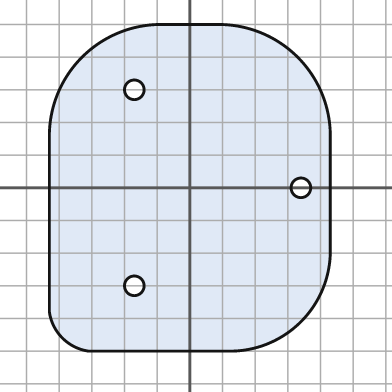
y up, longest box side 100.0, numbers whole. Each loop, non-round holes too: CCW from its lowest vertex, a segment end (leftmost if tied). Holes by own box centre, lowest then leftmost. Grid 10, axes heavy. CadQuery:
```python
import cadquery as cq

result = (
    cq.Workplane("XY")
    .moveTo(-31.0, -50.0)
    .lineTo(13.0, -50.0)
    .threePointArc((34.0, -41.0), (43.0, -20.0))
    .lineTo(43.0, 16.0)
    .threePointArc((33.0, 40.0), (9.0, 50.0))
    .lineTo(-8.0, 50.0)
    .threePointArc((-33.0, 40.0), (-43.0, 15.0))
    .lineTo(-43.0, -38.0)
    .threePointArc((-39.0, -46.0), (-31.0, -50.0))
    .close()
    .moveTo(-17.0, -30.0)
    .circle(3.0)
    .moveTo(34.0, 0.0)
    .circle(3.0)
    .moveTo(-17.0, 30.0)
    .circle(3.0)
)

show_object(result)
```